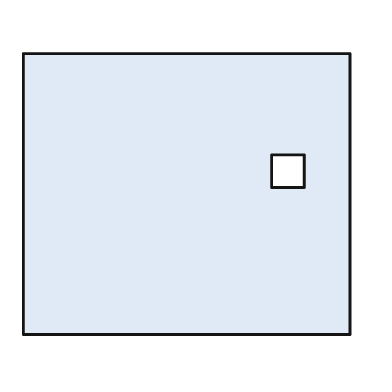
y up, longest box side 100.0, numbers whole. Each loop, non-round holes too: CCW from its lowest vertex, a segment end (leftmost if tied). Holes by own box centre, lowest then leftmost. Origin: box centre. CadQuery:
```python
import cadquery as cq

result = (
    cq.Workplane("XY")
    .moveTo(-50.0, -43.0)
    .lineTo(50.0, -43.0)
    .lineTo(50.0, 43.0)
    .lineTo(-50.0, 43.0)
    .close()
    .moveTo(26.0, 2.0)
    .lineTo(36.0, 2.0)
    .lineTo(36.0, 12.0)
    .lineTo(26.0, 12.0)
    .close()
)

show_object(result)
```